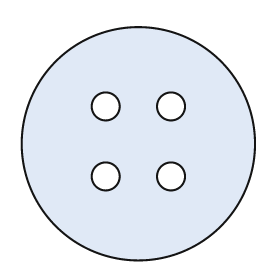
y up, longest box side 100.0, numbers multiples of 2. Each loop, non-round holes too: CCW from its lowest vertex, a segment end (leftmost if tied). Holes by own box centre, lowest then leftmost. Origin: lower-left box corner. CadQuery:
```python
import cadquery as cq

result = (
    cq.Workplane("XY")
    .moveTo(50.0, 50.0)
    .circle(50.0)
    .moveTo(36.0, 36.0)
    .circle(6.0)
    .moveTo(64.0, 36.0)
    .circle(6.0)
    .moveTo(36.0, 66.0)
    .circle(6.0)
    .moveTo(64.0, 66.0)
    .circle(6.0)
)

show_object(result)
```